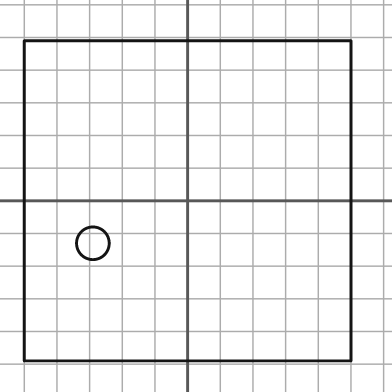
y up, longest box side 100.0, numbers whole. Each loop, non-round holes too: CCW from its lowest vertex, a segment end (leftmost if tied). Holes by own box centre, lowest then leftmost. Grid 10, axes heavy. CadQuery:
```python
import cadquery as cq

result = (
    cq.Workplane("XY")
    .moveTo(-50.0, -49.0)
    .lineTo(50.0, -49.0)
    .lineTo(50.0, 49.0)
    .lineTo(-50.0, 49.0)
    .close()
    .moveTo(-29.0, -13.0)
    .circle(5.0)
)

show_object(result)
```